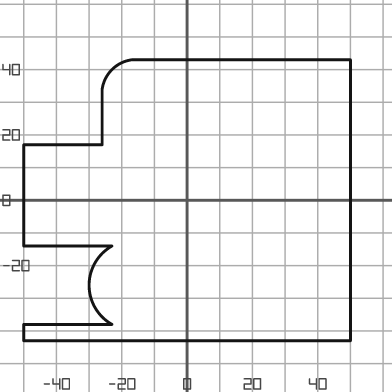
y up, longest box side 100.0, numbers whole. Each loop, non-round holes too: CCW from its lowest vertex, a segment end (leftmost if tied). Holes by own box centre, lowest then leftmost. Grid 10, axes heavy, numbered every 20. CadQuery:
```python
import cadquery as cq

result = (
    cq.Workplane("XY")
    .moveTo(-50.0, -43.0)
    .lineTo(50.0, -43.0)
    .lineTo(50.0, 43.0)
    .lineTo(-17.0, 43.0)
    .threePointArc((-23.0, 40.0), (-26.0, 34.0))
    .lineTo(-26.0, 17.0)
    .lineTo(-50.0, 17.0)
    .lineTo(-50.0, -14.0)
    .lineTo(-23.0, -14.0)
    .threePointArc((-30.0, -26.0), (-23.0, -38.0))
    .lineTo(-50.0, -38.0)
    .close()
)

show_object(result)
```